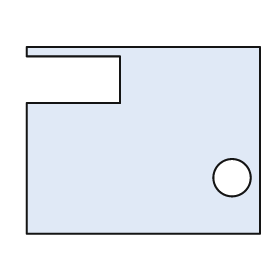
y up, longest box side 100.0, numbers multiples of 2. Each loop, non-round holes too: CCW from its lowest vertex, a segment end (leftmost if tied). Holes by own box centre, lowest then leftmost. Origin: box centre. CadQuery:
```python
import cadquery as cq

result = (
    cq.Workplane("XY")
    .moveTo(-50.0, -40.0)
    .lineTo(50.0, -40.0)
    .lineTo(50.0, 40.0)
    .lineTo(-50.0, 40.0)
    .lineTo(-50.0, 36.0)
    .lineTo(-10.0, 36.0)
    .lineTo(-10.0, 16.0)
    .lineTo(-50.0, 16.0)
    .close()
    .moveTo(38.0, -16.0)
    .circle(8.0)
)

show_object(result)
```